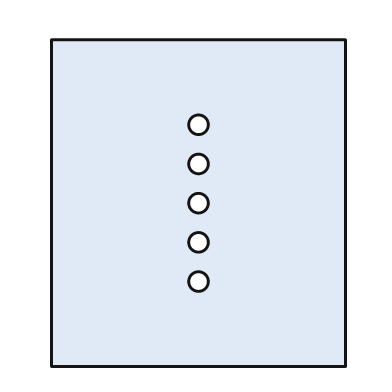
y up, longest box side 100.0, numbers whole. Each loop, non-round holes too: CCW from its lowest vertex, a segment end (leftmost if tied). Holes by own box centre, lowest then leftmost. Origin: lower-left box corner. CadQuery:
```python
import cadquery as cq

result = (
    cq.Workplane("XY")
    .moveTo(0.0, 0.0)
    .lineTo(90.0, 0.0)
    .lineTo(90.0, 100.0)
    .lineTo(0.0, 100.0)
    .close()
    .moveTo(45.0, 26.0)
    .circle(3.0)
    .moveTo(45.0, 38.0)
    .circle(3.0)
    .moveTo(45.0, 50.0)
    .circle(3.0)
    .moveTo(45.0, 62.0)
    .circle(3.0)
    .moveTo(45.0, 74.0)
    .circle(3.0)
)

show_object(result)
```